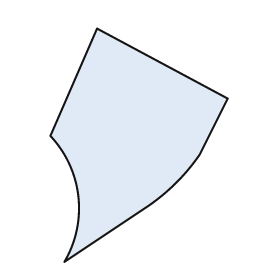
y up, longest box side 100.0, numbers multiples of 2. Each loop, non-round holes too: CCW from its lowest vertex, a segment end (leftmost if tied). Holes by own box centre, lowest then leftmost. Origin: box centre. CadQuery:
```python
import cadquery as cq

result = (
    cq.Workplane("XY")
    .moveTo(-32.0, -50.0)
    .lineTo(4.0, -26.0)
    .threePointArc((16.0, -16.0), (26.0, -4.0))
    .lineTo(38.0, 20.0)
    .lineTo(-18.0, 50.0)
    .lineTo(-38.0, 4.0)
    .threePointArc((-26.0, -22.0), (-32.0, -50.0))
    .close()
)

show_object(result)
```